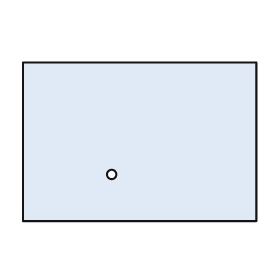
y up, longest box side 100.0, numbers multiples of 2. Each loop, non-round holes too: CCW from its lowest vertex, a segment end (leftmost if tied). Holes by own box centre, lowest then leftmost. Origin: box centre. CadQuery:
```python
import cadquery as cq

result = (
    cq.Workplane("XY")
    .moveTo(-50.0, -34.0)
    .lineTo(50.0, -34.0)
    .lineTo(50.0, 34.0)
    .lineTo(-50.0, 34.0)
    .close()
    .moveTo(-12.0, -14.0)
    .circle(2.0)
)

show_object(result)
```